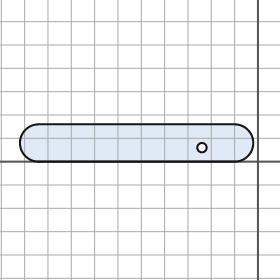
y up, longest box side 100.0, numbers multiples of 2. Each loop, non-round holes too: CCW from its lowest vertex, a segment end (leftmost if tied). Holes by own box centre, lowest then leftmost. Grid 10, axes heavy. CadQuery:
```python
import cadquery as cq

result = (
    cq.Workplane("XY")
    .moveTo(-94.0, 0.0)
    .lineTo(-10.0, 0.0)
    .threePointArc((-2.0, 8.0), (-10.0, 16.0))
    .lineTo(-94.0, 16.0)
    .threePointArc((-102.0, 8.0), (-94.0, 0.0))
    .close()
    .moveTo(-24.0, 6.0)
    .circle(2.0)
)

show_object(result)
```